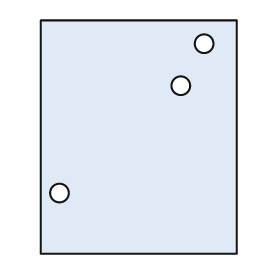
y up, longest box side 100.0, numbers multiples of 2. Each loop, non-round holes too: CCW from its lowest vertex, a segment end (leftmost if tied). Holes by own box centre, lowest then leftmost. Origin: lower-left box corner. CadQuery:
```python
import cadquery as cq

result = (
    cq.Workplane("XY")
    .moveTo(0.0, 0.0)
    .lineTo(84.0, 0.0)
    .lineTo(84.0, 100.0)
    .lineTo(0.0, 100.0)
    .close()
    .moveTo(8.0, 26.0)
    .circle(4.0)
    .moveTo(60.0, 72.0)
    .circle(4.0)
    .moveTo(70.0, 90.0)
    .circle(4.0)
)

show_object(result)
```